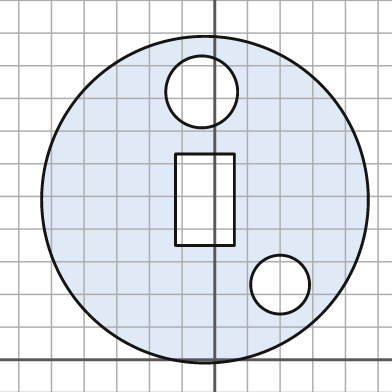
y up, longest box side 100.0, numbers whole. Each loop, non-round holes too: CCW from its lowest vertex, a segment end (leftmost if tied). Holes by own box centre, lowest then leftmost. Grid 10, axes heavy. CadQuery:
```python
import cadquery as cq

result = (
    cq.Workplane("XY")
    .moveTo(-3.0, 49.0)
    .circle(50.0)
    .moveTo(20.0, 23.0)
    .circle(9.0)
    .moveTo(-12.0, 35.0)
    .lineTo(6.0, 35.0)
    .lineTo(6.0, 63.0)
    .lineTo(-12.0, 63.0)
    .close()
    .moveTo(-4.0, 82.0)
    .circle(11.0)
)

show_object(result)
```